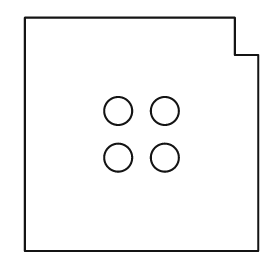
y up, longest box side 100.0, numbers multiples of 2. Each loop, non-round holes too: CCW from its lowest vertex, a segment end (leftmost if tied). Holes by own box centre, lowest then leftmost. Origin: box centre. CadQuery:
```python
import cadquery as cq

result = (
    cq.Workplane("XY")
    .moveTo(-50.0, -50.0)
    .lineTo(50.0, -50.0)
    .lineTo(50.0, 34.0)
    .lineTo(40.0, 34.0)
    .lineTo(40.0, 50.0)
    .lineTo(-50.0, 50.0)
    .close()
    .moveTo(-10.0, -10.0)
    .circle(6.0)
    .moveTo(10.0, -10.0)
    .circle(6.0)
    .moveTo(-10.0, 10.0)
    .circle(6.0)
    .moveTo(10.0, 10.0)
    .circle(6.0)
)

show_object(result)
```